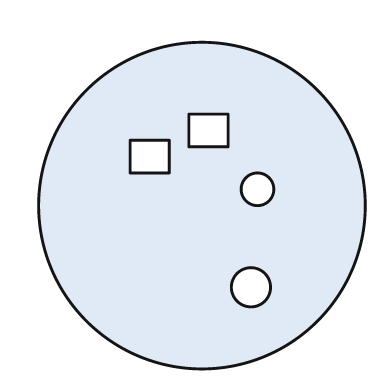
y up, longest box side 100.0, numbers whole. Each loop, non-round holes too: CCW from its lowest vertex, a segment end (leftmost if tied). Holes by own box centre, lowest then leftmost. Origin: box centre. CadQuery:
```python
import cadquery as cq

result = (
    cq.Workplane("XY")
    .moveTo(0.0, 0.0)
    .circle(50.0)
    .moveTo(15.0, -25.0)
    .circle(6.0)
    .moveTo(17.0, 5.0)
    .circle(5.0)
    .moveTo(-22.0, 10.0)
    .lineTo(-10.0, 10.0)
    .lineTo(-10.0, 20.0)
    .lineTo(-22.0, 20.0)
    .close()
    .moveTo(-4.0, 18.0)
    .lineTo(8.0, 18.0)
    .lineTo(8.0, 28.0)
    .lineTo(-4.0, 28.0)
    .close()
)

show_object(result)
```